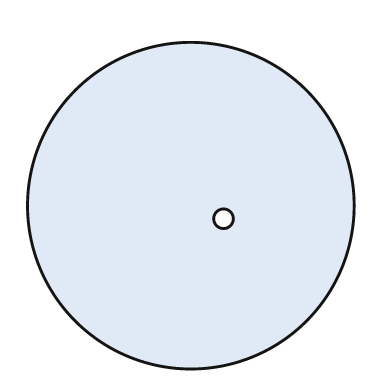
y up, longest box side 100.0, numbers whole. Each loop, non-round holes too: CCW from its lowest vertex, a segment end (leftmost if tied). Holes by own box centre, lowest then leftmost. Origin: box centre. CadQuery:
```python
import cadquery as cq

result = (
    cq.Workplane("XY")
    .moveTo(0.0, 0.0)
    .circle(50.0)
    .moveTo(10.0, -4.0)
    .circle(3.0)
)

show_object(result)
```